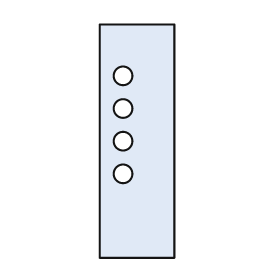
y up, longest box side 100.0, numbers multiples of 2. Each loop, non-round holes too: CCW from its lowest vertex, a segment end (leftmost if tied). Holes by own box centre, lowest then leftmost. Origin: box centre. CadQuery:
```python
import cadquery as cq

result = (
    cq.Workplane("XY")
    .moveTo(-16.0, -50.0)
    .lineTo(16.0, -50.0)
    .lineTo(16.0, 50.0)
    .lineTo(-16.0, 50.0)
    .close()
    .moveTo(-6.0, -14.0)
    .circle(4.0)
    .moveTo(-6.0, 0.0)
    .circle(4.0)
    .moveTo(-6.0, 14.0)
    .circle(4.0)
    .moveTo(-6.0, 28.0)
    .circle(4.0)
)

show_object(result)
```